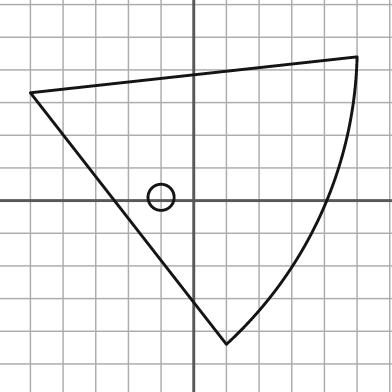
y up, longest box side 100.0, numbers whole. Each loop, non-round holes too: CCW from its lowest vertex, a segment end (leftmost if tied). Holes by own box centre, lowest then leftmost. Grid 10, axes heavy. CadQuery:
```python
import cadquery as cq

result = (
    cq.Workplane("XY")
    .moveTo(10.0, -44.0)
    .threePointArc((39.0, -4.0), (50.0, 44.0))
    .lineTo(-50.0, 33.0)
    .close()
    .moveTo(-10.0, 1.0)
    .circle(4.0)
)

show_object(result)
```